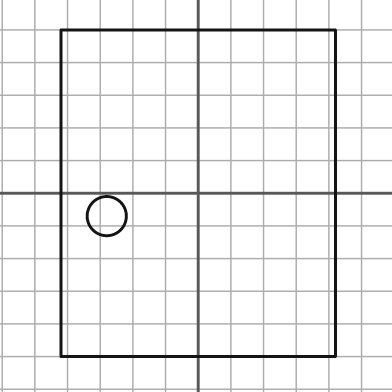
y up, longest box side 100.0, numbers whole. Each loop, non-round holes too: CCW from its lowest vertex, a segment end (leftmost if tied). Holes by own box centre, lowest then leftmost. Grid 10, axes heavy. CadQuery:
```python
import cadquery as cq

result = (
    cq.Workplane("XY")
    .moveTo(-42.0, -50.0)
    .lineTo(42.0, -50.0)
    .lineTo(42.0, 50.0)
    .lineTo(-42.0, 50.0)
    .close()
    .moveTo(-28.0, -7.0)
    .circle(6.0)
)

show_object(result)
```